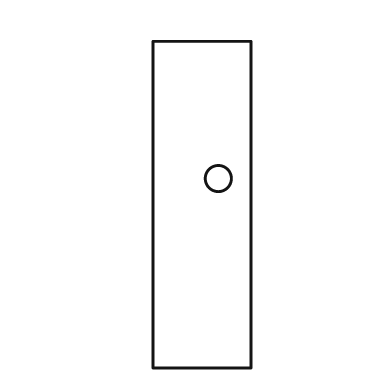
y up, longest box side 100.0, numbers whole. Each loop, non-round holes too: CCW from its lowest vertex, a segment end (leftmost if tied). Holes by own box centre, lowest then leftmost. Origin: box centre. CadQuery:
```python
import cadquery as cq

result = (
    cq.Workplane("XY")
    .moveTo(-15.0, -50.0)
    .lineTo(15.0, -50.0)
    .lineTo(15.0, 50.0)
    .lineTo(-15.0, 50.0)
    .close()
    .moveTo(5.0, 8.0)
    .circle(4.0)
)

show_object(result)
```